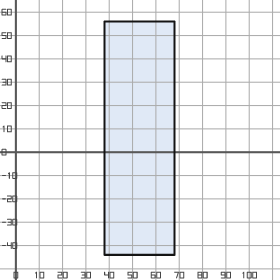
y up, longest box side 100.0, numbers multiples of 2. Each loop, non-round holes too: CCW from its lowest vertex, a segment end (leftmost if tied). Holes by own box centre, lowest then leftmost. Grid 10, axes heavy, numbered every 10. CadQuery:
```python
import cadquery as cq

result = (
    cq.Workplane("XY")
    .moveTo(38.0, -44.0)
    .lineTo(68.0, -44.0)
    .lineTo(68.0, 56.0)
    .lineTo(38.0, 56.0)
    .close()
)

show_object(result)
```